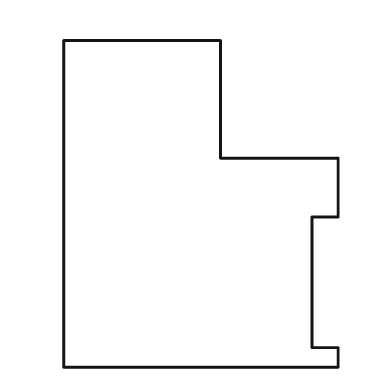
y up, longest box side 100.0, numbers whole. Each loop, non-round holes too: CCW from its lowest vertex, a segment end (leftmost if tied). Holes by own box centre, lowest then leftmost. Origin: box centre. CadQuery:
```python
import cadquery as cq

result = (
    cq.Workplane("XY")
    .moveTo(-42.0, -50.0)
    .lineTo(42.0, -50.0)
    .lineTo(42.0, -44.0)
    .lineTo(34.0, -44.0)
    .lineTo(34.0, -4.0)
    .lineTo(42.0, -4.0)
    .lineTo(42.0, 14.0)
    .lineTo(6.0, 14.0)
    .lineTo(6.0, 50.0)
    .lineTo(-42.0, 50.0)
    .close()
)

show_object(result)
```